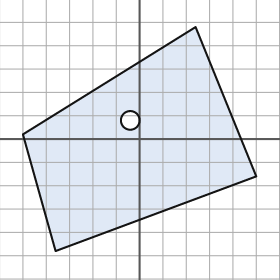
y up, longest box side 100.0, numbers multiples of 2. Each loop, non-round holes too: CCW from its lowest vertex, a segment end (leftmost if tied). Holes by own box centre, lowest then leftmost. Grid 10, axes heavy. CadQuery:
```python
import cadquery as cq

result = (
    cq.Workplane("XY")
    .moveTo(-36.0, -48.0)
    .lineTo(50.0, -16.0)
    .lineTo(24.0, 48.0)
    .lineTo(-50.0, 2.0)
    .close()
    .moveTo(-4.0, 8.0)
    .circle(4.0)
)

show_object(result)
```